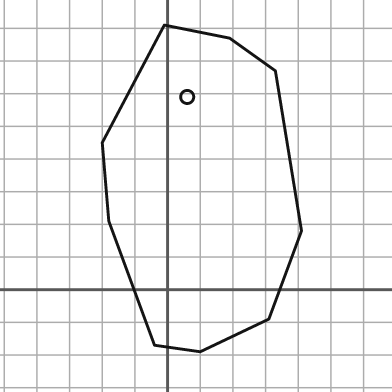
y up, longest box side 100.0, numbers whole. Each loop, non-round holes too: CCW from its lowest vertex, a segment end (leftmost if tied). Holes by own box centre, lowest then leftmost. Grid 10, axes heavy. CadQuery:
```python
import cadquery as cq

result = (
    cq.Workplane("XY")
    .moveTo(10.0, -19.0)
    .lineTo(31.0, -9.0)
    .lineTo(41.0, 18.0)
    .lineTo(33.0, 67.0)
    .lineTo(19.0, 77.0)
    .lineTo(-1.0, 81.0)
    .lineTo(-20.0, 45.0)
    .lineTo(-18.0, 21.0)
    .lineTo(-4.0, -17.0)
    .close()
    .moveTo(6.0, 59.0)
    .circle(2.0)
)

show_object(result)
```